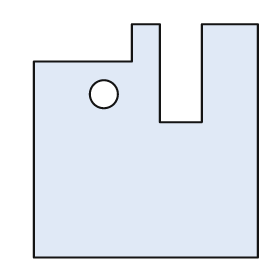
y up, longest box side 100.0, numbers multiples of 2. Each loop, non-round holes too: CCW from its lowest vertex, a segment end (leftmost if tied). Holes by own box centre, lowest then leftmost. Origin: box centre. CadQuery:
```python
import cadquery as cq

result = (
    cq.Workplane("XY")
    .moveTo(-48.0, -50.0)
    .lineTo(48.0, -50.0)
    .lineTo(48.0, 50.0)
    .lineTo(24.0, 50.0)
    .lineTo(24.0, 8.0)
    .lineTo(6.0, 8.0)
    .lineTo(6.0, 50.0)
    .lineTo(-6.0, 50.0)
    .lineTo(-6.0, 34.0)
    .lineTo(-48.0, 34.0)
    .close()
    .moveTo(-18.0, 20.0)
    .circle(6.0)
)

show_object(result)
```